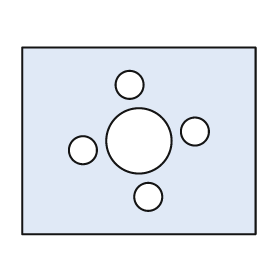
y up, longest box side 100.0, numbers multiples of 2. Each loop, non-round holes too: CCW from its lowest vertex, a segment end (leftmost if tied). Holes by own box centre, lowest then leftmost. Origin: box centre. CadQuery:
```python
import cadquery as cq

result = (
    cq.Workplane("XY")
    .moveTo(-50.0, -40.0)
    .lineTo(50.0, -40.0)
    .lineTo(50.0, 40.0)
    .lineTo(-50.0, 40.0)
    .close()
    .moveTo(4.0, -24.0)
    .circle(6.0)
    .moveTo(-24.0, -4.0)
    .circle(6.0)
    .moveTo(0.0, 0.0)
    .circle(14.0)
    .moveTo(24.0, 4.0)
    .circle(6.0)
    .moveTo(-4.0, 24.0)
    .circle(6.0)
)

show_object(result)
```